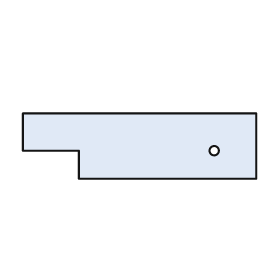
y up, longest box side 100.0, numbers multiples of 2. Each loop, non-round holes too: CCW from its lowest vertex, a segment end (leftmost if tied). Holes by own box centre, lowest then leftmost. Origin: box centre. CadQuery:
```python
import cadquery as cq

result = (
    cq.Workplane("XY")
    .moveTo(-26.0, -14.0)
    .lineTo(50.0, -14.0)
    .lineTo(50.0, 14.0)
    .lineTo(-50.0, 14.0)
    .lineTo(-50.0, -2.0)
    .lineTo(-26.0, -2.0)
    .close()
    .moveTo(32.0, -2.0)
    .circle(2.0)
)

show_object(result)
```